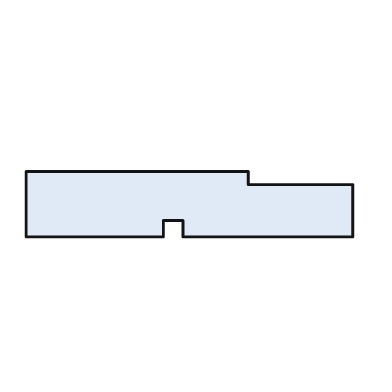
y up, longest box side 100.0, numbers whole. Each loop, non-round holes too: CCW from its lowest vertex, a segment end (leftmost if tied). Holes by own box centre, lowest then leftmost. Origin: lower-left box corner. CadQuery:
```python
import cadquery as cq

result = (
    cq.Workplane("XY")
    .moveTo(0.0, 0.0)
    .lineTo(42.0, 0.0)
    .lineTo(42.0, 5.0)
    .lineTo(48.0, 5.0)
    .lineTo(48.0, 0.0)
    .lineTo(100.0, 0.0)
    .lineTo(100.0, 16.0)
    .lineTo(68.0, 16.0)
    .lineTo(68.0, 20.0)
    .lineTo(0.0, 20.0)
    .close()
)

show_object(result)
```